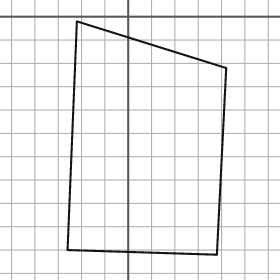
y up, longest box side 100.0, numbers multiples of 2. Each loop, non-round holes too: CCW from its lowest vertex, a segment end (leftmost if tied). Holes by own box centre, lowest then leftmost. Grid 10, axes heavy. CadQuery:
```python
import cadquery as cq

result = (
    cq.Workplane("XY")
    .moveTo(38.0, -102.0)
    .lineTo(42.0, -22.0)
    .lineTo(-22.0, -2.0)
    .lineTo(-26.0, -100.0)
    .close()
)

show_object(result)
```